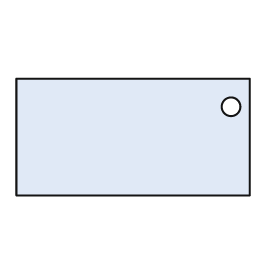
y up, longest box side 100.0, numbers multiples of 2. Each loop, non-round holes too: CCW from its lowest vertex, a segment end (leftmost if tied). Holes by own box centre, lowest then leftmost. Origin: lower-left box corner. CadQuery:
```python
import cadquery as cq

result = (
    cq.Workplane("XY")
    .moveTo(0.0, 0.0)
    .lineTo(100.0, 0.0)
    .lineTo(100.0, 50.0)
    .lineTo(0.0, 50.0)
    .close()
    .moveTo(92.0, 38.0)
    .circle(4.0)
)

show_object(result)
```